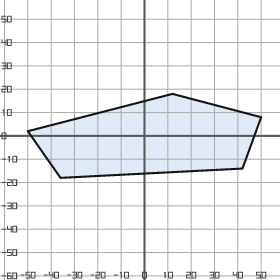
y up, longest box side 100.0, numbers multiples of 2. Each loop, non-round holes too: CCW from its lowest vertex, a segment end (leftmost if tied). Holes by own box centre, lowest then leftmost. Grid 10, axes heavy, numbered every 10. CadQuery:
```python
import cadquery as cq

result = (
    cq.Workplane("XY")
    .moveTo(-36.0, -18.0)
    .lineTo(42.0, -14.0)
    .lineTo(50.0, 8.0)
    .lineTo(12.0, 18.0)
    .lineTo(-50.0, 2.0)
    .close()
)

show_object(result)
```